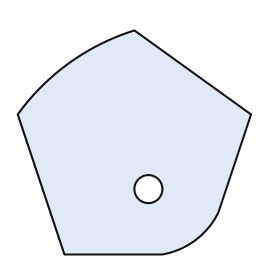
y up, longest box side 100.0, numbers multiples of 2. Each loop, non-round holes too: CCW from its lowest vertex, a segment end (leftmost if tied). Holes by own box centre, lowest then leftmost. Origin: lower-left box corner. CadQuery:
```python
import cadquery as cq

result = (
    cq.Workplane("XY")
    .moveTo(20.0, 0.0)
    .lineTo(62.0, 0.0)
    .threePointArc((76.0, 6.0), (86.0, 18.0))
    .lineTo(100.0, 60.0)
    .lineTo(50.0, 96.0)
    .threePointArc((22.0, 82.0), (0.0, 60.0))
    .close()
    .moveTo(56.0, 28.0)
    .circle(6.0)
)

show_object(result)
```